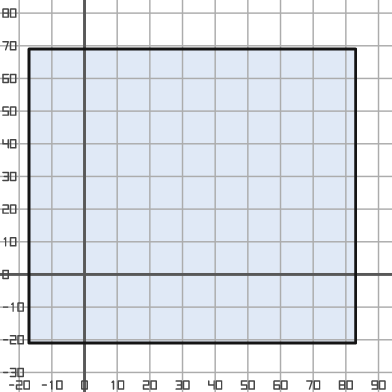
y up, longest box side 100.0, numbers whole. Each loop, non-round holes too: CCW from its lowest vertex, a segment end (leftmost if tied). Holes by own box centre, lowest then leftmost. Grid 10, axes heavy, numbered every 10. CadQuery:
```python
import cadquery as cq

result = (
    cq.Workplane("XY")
    .moveTo(-17.0, -21.0)
    .lineTo(83.0, -21.0)
    .lineTo(83.0, 69.0)
    .lineTo(-17.0, 69.0)
    .close()
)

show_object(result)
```